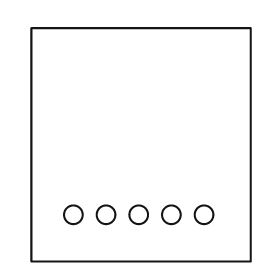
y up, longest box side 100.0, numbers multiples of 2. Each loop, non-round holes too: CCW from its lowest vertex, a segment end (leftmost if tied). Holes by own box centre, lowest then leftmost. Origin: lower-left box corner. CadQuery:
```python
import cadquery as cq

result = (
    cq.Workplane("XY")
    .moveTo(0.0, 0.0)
    .lineTo(94.0, 0.0)
    .lineTo(94.0, 100.0)
    .lineTo(0.0, 100.0)
    .close()
    .moveTo(18.0, 20.0)
    .circle(4.0)
    .moveTo(32.0, 20.0)
    .circle(4.0)
    .moveTo(46.0, 20.0)
    .circle(4.0)
    .moveTo(60.0, 20.0)
    .circle(4.0)
    .moveTo(74.0, 20.0)
    .circle(4.0)
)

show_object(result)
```